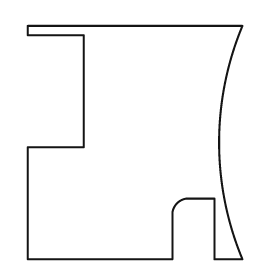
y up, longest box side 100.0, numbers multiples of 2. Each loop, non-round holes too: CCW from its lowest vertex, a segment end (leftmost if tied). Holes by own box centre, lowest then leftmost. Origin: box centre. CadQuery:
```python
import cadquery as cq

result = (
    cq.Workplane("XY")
    .moveTo(-46.0, -50.0)
    .lineTo(16.0, -50.0)
    .lineTo(16.0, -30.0)
    .threePointArc((18.0, -26.0), (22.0, -24.0))
    .lineTo(34.0, -24.0)
    .lineTo(34.0, -50.0)
    .lineTo(46.0, -50.0)
    .threePointArc((36.0, 0.0), (46.0, 50.0))
    .lineTo(-46.0, 50.0)
    .lineTo(-46.0, 46.0)
    .lineTo(-22.0, 46.0)
    .lineTo(-22.0, -2.0)
    .lineTo(-46.0, -2.0)
    .close()
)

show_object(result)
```